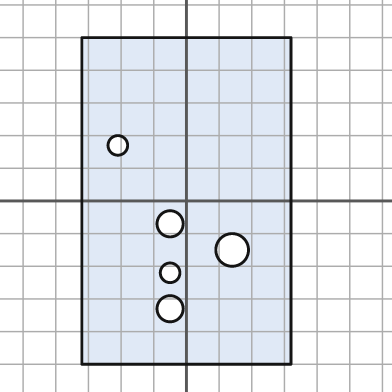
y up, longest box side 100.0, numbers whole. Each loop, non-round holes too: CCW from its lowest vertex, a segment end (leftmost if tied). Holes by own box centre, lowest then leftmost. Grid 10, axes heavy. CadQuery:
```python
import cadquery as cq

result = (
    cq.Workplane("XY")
    .moveTo(-32.0, -50.0)
    .lineTo(32.0, -50.0)
    .lineTo(32.0, 50.0)
    .lineTo(-32.0, 50.0)
    .close()
    .moveTo(-5.0, -33.0)
    .circle(4.0)
    .moveTo(-5.0, -22.0)
    .circle(3.0)
    .moveTo(14.0, -15.0)
    .circle(5.0)
    .moveTo(-5.0, -7.0)
    .circle(4.0)
    .moveTo(-21.0, 17.0)
    .circle(3.0)
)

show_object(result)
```